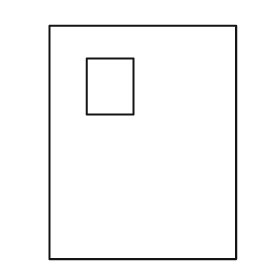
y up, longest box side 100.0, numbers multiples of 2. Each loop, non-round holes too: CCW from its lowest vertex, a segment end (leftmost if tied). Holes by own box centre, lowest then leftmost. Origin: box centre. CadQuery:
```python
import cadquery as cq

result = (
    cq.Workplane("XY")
    .moveTo(-40.0, -50.0)
    .lineTo(40.0, -50.0)
    .lineTo(40.0, 50.0)
    .lineTo(-40.0, 50.0)
    .close()
    .moveTo(-24.0, 12.0)
    .lineTo(-4.0, 12.0)
    .lineTo(-4.0, 36.0)
    .lineTo(-24.0, 36.0)
    .close()
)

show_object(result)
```